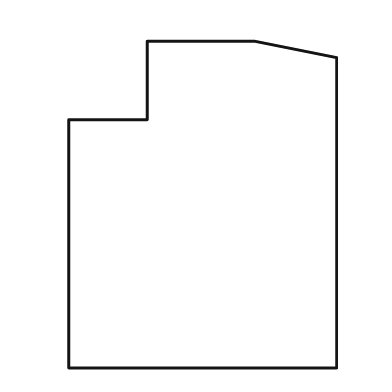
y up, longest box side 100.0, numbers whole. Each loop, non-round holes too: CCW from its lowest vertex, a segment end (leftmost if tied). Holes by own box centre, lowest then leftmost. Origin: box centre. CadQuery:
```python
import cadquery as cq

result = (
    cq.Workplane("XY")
    .moveTo(-41.0, -50.0)
    .lineTo(41.0, -50.0)
    .lineTo(41.0, 45.0)
    .lineTo(16.0, 50.0)
    .lineTo(-17.0, 50.0)
    .lineTo(-17.0, 26.0)
    .lineTo(-41.0, 26.0)
    .close()
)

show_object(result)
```